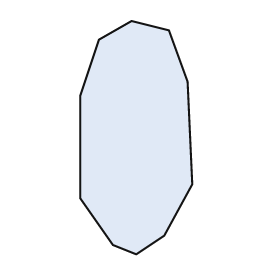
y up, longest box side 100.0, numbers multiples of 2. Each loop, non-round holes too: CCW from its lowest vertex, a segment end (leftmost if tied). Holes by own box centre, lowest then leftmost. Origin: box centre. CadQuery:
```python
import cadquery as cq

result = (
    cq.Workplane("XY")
    .moveTo(0.0, -50.0)
    .lineTo(12.0, -42.0)
    .lineTo(24.0, -20.0)
    .lineTo(22.0, 24.0)
    .lineTo(14.0, 46.0)
    .lineTo(-2.0, 50.0)
    .lineTo(-16.0, 42.0)
    .lineTo(-24.0, 18.0)
    .lineTo(-24.0, -26.0)
    .lineTo(-10.0, -46.0)
    .close()
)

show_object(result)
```